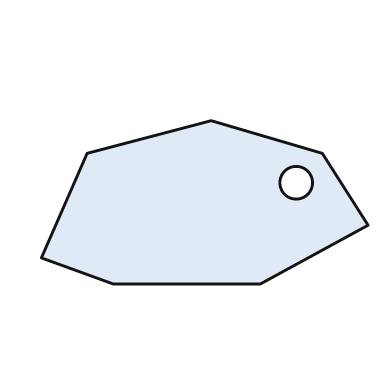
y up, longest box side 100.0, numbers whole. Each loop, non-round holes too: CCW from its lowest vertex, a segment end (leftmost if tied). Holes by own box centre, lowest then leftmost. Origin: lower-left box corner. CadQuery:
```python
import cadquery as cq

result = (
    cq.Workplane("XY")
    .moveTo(22.0, 0.0)
    .lineTo(67.0, 0.0)
    .lineTo(100.0, 18.0)
    .lineTo(86.0, 40.0)
    .lineTo(52.0, 50.0)
    .lineTo(14.0, 40.0)
    .lineTo(0.0, 8.0)
    .close()
    .moveTo(78.0, 31.0)
    .circle(5.0)
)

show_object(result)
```